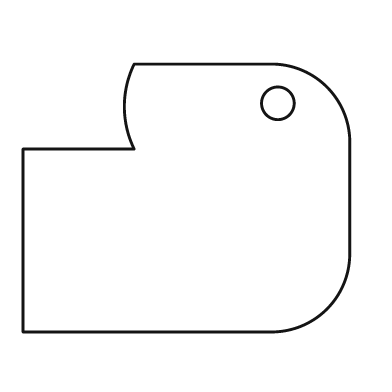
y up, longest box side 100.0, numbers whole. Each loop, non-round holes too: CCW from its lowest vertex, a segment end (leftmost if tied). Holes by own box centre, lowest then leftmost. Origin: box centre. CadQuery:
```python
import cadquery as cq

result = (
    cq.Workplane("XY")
    .moveTo(-50.0, -41.0)
    .lineTo(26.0, -41.0)
    .threePointArc((43.0, -34.0), (50.0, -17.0))
    .lineTo(50.0, 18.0)
    .threePointArc((43.0, 34.0), (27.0, 41.0))
    .lineTo(-16.0, 41.0)
    .threePointArc((-19.0, 28.0), (-16.0, 15.0))
    .lineTo(-50.0, 15.0)
    .close()
    .moveTo(28.0, 29.0)
    .circle(5.0)
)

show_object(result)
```